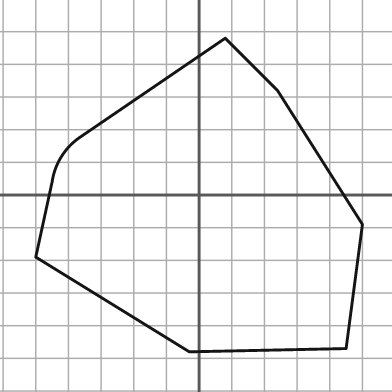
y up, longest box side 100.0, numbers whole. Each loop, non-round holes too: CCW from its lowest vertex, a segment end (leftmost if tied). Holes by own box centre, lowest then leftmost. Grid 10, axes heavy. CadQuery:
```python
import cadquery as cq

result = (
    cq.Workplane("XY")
    .moveTo(-3.0, -48.0)
    .lineTo(45.0, -47.0)
    .lineTo(50.0, -9.0)
    .lineTo(24.0, 32.0)
    .lineTo(8.0, 48.0)
    .lineTo(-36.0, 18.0)
    .threePointArc((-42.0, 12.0), (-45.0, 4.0))
    .lineTo(-50.0, -19.0)
    .close()
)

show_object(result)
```